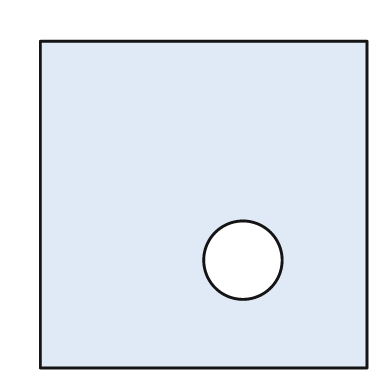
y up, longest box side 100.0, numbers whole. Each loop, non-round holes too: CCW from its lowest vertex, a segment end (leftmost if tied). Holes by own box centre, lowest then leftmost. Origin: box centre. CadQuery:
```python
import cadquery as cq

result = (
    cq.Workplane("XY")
    .moveTo(-50.0, -50.0)
    .lineTo(50.0, -50.0)
    .lineTo(50.0, 50.0)
    .lineTo(-50.0, 50.0)
    .close()
    .moveTo(12.0, -17.0)
    .circle(12.0)
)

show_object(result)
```